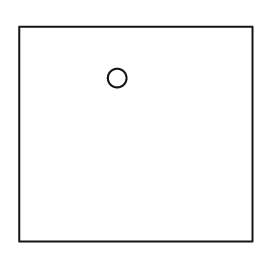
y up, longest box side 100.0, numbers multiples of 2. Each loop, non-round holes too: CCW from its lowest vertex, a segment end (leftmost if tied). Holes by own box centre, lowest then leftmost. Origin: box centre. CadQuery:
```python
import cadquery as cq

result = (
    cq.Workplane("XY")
    .moveTo(-50.0, -46.0)
    .lineTo(50.0, -46.0)
    .lineTo(50.0, 46.0)
    .lineTo(-50.0, 46.0)
    .close()
    .moveTo(-8.0, 24.0)
    .circle(4.0)
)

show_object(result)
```